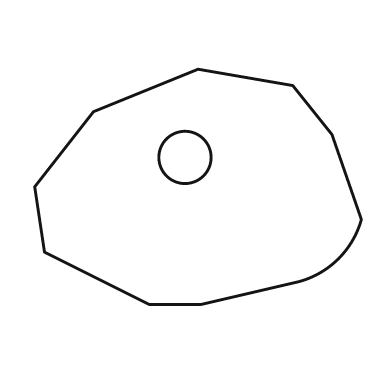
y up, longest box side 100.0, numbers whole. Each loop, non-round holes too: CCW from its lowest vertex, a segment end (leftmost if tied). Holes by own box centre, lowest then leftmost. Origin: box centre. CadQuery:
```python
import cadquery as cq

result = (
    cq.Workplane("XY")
    .moveTo(-15.0, -36.0)
    .lineTo(1.0, -36.0)
    .lineTo(31.0, -29.0)
    .threePointArc((43.0, -22.0), (50.0, -10.0))
    .lineTo(41.0, 16.0)
    .lineTo(29.0, 31.0)
    .lineTo(0.0, 36.0)
    .lineTo(-32.0, 23.0)
    .lineTo(-50.0, 0.0)
    .lineTo(-47.0, -20.0)
    .close()
    .moveTo(-4.0, 9.0)
    .circle(8.0)
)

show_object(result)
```